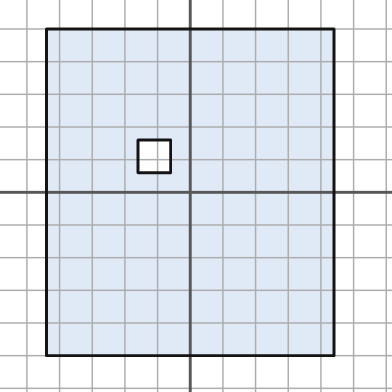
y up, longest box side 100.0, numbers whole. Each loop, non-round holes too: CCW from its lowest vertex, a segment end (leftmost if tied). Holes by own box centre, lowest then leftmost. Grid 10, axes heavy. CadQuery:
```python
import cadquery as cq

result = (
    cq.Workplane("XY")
    .moveTo(-44.0, -50.0)
    .lineTo(44.0, -50.0)
    .lineTo(44.0, 50.0)
    .lineTo(-44.0, 50.0)
    .close()
    .moveTo(-16.0, 6.0)
    .lineTo(-6.0, 6.0)
    .lineTo(-6.0, 16.0)
    .lineTo(-16.0, 16.0)
    .close()
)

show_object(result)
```